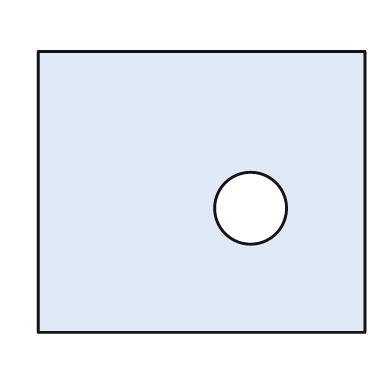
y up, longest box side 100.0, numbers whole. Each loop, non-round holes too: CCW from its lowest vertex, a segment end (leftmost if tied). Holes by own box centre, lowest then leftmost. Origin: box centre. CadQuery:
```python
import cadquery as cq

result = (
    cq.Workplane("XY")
    .moveTo(-50.0, -43.0)
    .lineTo(50.0, -43.0)
    .lineTo(50.0, 43.0)
    .lineTo(-50.0, 43.0)
    .close()
    .moveTo(15.0, -5.0)
    .circle(11.0)
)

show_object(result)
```